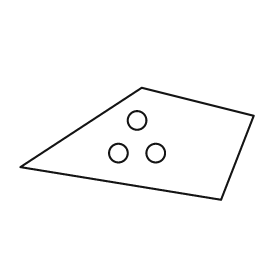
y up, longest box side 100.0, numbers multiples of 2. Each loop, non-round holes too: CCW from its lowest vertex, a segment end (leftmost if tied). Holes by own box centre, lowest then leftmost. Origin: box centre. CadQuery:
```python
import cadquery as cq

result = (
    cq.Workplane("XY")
    .moveTo(36.0, -24.0)
    .lineTo(50.0, 12.0)
    .lineTo(2.0, 24.0)
    .lineTo(-50.0, -10.0)
    .close()
    .moveTo(-8.0, -4.0)
    .circle(4.0)
    .moveTo(8.0, -4.0)
    .circle(4.0)
    .moveTo(0.0, 10.0)
    .circle(4.0)
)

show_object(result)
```